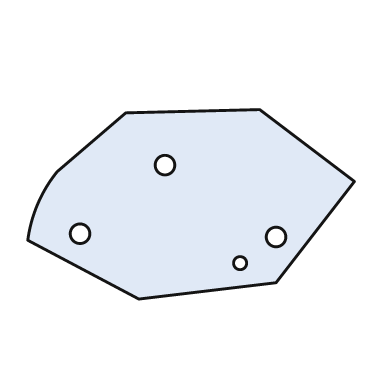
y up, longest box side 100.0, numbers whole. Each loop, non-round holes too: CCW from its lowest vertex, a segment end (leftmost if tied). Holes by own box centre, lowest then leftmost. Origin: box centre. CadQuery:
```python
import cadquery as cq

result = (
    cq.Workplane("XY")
    .moveTo(-16.0, -29.0)
    .lineTo(26.0, -24.0)
    .lineTo(50.0, 7.0)
    .lineTo(21.0, 29.0)
    .lineTo(-20.0, 28.0)
    .lineTo(-41.0, 10.0)
    .threePointArc((-47.0, 0.0), (-50.0, -11.0))
    .close()
    .moveTo(15.0, -18.0)
    .circle(2.0)
    .moveTo(26.0, -10.0)
    .circle(3.0)
    .moveTo(-34.0, -9.0)
    .circle(3.0)
    .moveTo(-8.0, 12.0)
    .circle(3.0)
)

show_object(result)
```